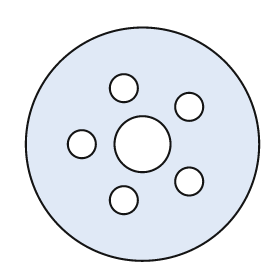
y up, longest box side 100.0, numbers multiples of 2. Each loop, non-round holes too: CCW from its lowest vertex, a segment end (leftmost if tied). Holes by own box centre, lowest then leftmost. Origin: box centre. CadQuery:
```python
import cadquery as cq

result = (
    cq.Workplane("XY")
    .moveTo(0.0, 0.0)
    .circle(50.0)
    .moveTo(-8.0, -24.0)
    .circle(6.0)
    .moveTo(20.0, -16.0)
    .circle(6.0)
    .moveTo(-26.0, 0.0)
    .circle(6.0)
    .moveTo(0.0, 0.0)
    .circle(12.0)
    .moveTo(20.0, 16.0)
    .circle(6.0)
    .moveTo(-8.0, 24.0)
    .circle(6.0)
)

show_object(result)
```